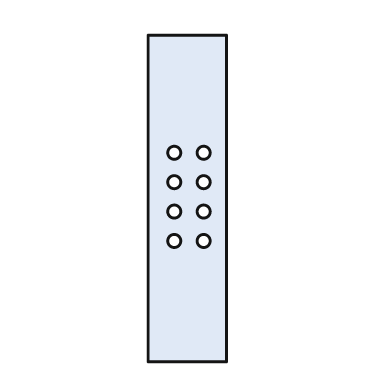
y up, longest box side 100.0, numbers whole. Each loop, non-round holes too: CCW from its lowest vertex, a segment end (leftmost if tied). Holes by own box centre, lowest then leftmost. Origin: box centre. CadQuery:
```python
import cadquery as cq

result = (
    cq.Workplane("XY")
    .moveTo(-12.0, -50.0)
    .lineTo(12.0, -50.0)
    .lineTo(12.0, 50.0)
    .lineTo(-12.0, 50.0)
    .close()
    .moveTo(-4.0, -13.0)
    .circle(2.0)
    .moveTo(5.0, -13.0)
    .circle(2.0)
    .moveTo(-4.0, -4.0)
    .circle(2.0)
    .moveTo(5.0, -4.0)
    .circle(2.0)
    .moveTo(-4.0, 5.0)
    .circle(2.0)
    .moveTo(5.0, 5.0)
    .circle(2.0)
    .moveTo(-4.0, 14.0)
    .circle(2.0)
    .moveTo(5.0, 14.0)
    .circle(2.0)
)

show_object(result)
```